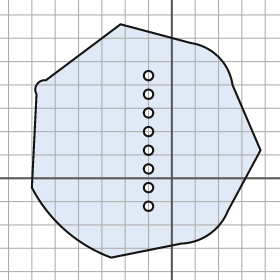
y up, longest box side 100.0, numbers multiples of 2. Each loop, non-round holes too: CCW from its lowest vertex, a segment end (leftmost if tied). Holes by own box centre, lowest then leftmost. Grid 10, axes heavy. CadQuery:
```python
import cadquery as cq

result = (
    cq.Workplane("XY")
    .moveTo(-26.0, -34.0)
    .lineTo(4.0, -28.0)
    .threePointArc((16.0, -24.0), (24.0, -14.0))
    .lineTo(38.0, 12.0)
    .lineTo(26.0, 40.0)
    .threePointArc((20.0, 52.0), (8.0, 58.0))
    .lineTo(-22.0, 66.0)
    .lineTo(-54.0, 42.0)
    .threePointArc((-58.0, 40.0), (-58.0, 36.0))
    .lineTo(-60.0, -4.0)
    .threePointArc((-46.0, -22.0), (-26.0, -34.0))
    .close()
    .moveTo(-10.0, -12.0)
    .circle(2.0)
    .moveTo(-10.0, -4.0)
    .circle(2.0)
    .moveTo(-10.0, 4.0)
    .circle(2.0)
    .moveTo(-10.0, 12.0)
    .circle(2.0)
    .moveTo(-10.0, 20.0)
    .circle(2.0)
    .moveTo(-10.0, 28.0)
    .circle(2.0)
    .moveTo(-10.0, 36.0)
    .circle(2.0)
    .moveTo(-10.0, 44.0)
    .circle(2.0)
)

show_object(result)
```